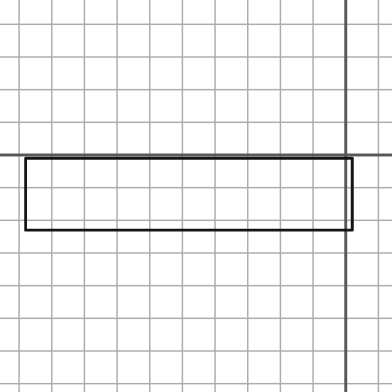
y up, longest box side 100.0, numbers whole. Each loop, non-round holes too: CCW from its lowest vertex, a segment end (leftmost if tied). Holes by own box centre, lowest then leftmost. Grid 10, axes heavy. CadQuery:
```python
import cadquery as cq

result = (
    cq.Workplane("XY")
    .moveTo(-98.0, -23.0)
    .lineTo(2.0, -23.0)
    .lineTo(2.0, -1.0)
    .lineTo(-98.0, -1.0)
    .close()
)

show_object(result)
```